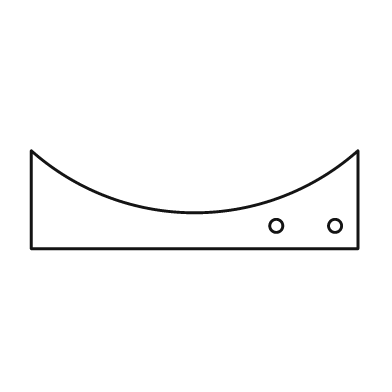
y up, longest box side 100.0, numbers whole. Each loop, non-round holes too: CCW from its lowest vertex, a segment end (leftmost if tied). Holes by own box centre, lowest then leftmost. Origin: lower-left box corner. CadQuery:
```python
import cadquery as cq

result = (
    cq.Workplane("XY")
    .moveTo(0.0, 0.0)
    .lineTo(100.0, 0.0)
    .lineTo(100.0, 30.0)
    .threePointArc((50.0, 11.0), (0.0, 30.0))
    .close()
    .moveTo(75.0, 7.0)
    .circle(2.0)
    .moveTo(93.0, 7.0)
    .circle(2.0)
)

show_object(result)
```